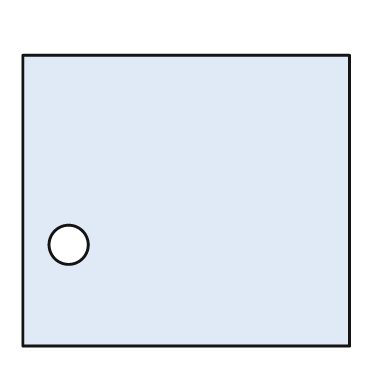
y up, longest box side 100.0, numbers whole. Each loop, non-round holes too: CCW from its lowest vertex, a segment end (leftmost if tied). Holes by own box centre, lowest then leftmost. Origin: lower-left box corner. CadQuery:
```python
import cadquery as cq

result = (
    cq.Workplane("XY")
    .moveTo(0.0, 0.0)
    .lineTo(100.0, 0.0)
    .lineTo(100.0, 89.0)
    .lineTo(0.0, 89.0)
    .close()
    .moveTo(14.0, 31.0)
    .circle(6.0)
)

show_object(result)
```